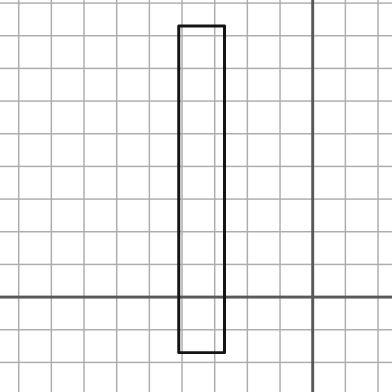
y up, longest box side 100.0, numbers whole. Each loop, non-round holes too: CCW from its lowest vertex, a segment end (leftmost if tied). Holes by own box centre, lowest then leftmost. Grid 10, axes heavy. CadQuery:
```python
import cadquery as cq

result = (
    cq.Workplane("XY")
    .moveTo(-41.0, -17.0)
    .lineTo(-27.0, -17.0)
    .lineTo(-27.0, 83.0)
    .lineTo(-41.0, 83.0)
    .close()
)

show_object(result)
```